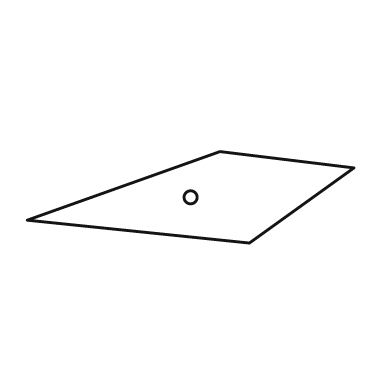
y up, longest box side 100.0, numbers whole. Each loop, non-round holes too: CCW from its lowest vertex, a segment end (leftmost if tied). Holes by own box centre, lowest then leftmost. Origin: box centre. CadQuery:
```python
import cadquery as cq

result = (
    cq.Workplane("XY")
    .moveTo(18.0, -14.0)
    .lineTo(50.0, 9.0)
    .lineTo(9.0, 14.0)
    .lineTo(-50.0, -7.0)
    .close()
    .moveTo(0.0, 0.0)
    .circle(2.0)
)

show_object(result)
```